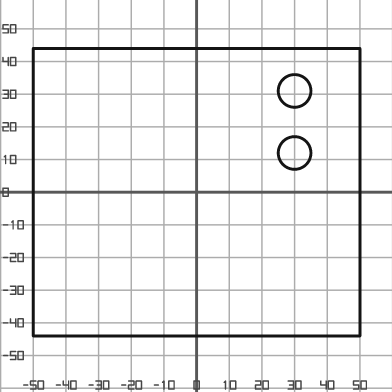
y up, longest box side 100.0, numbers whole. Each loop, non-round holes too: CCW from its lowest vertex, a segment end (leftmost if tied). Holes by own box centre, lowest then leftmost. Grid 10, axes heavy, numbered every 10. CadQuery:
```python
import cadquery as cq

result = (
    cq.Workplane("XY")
    .moveTo(-50.0, -44.0)
    .lineTo(50.0, -44.0)
    .lineTo(50.0, 44.0)
    .lineTo(-50.0, 44.0)
    .close()
    .moveTo(30.0, 12.0)
    .circle(5.0)
    .moveTo(30.0, 31.0)
    .circle(5.0)
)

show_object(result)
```